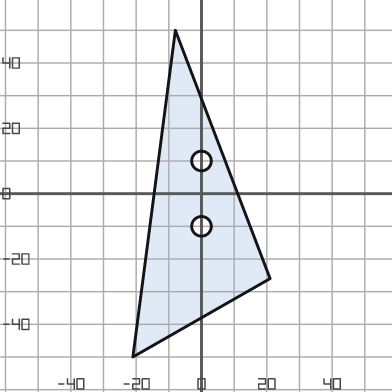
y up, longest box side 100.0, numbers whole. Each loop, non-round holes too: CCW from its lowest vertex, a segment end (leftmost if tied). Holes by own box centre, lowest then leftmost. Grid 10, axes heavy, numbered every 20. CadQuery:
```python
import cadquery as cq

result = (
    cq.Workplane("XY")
    .moveTo(-21.0, -50.0)
    .lineTo(21.0, -26.0)
    .lineTo(-8.0, 50.0)
    .close()
    .moveTo(0.0, -10.0)
    .circle(3.0)
    .moveTo(0.0, 10.0)
    .circle(3.0)
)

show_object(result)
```